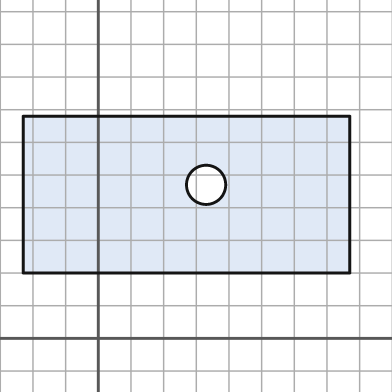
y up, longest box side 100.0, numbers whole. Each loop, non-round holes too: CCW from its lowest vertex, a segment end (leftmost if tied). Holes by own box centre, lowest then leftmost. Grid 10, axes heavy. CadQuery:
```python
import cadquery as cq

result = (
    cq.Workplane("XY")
    .moveTo(-23.0, 20.0)
    .lineTo(77.0, 20.0)
    .lineTo(77.0, 68.0)
    .lineTo(-23.0, 68.0)
    .close()
    .moveTo(33.0, 47.0)
    .circle(6.0)
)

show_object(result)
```